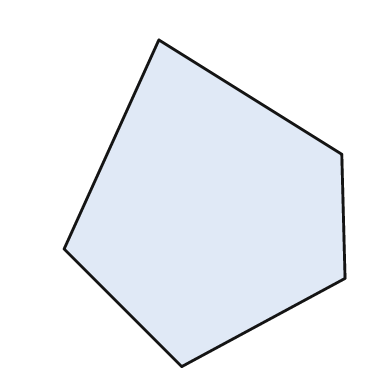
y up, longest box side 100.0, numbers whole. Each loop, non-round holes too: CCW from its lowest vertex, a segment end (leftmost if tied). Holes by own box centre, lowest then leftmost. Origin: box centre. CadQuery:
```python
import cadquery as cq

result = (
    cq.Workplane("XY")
    .moveTo(-7.0, -50.0)
    .lineTo(43.0, -23.0)
    .lineTo(42.0, 15.0)
    .lineTo(-14.0, 50.0)
    .lineTo(-43.0, -14.0)
    .close()
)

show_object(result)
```